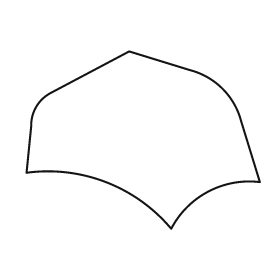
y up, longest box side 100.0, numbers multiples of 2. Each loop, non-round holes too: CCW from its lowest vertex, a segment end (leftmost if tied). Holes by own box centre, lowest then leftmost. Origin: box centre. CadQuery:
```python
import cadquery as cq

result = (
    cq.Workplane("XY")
    .moveTo(12.0, -38.0)
    .threePointArc((28.0, -22.0), (50.0, -18.0))
    .lineTo(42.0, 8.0)
    .threePointArc((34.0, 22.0), (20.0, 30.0))
    .lineTo(-6.0, 38.0)
    .lineTo(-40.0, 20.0)
    .threePointArc((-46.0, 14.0), (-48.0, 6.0))
    .lineTo(-50.0, -14.0)
    .threePointArc((-16.0, -18.0), (12.0, -38.0))
    .close()
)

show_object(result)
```